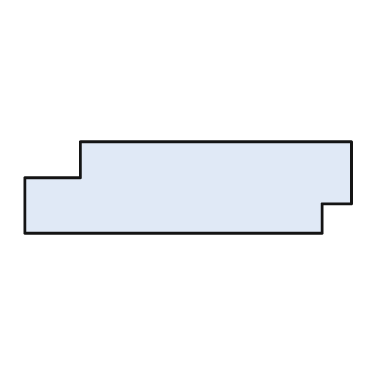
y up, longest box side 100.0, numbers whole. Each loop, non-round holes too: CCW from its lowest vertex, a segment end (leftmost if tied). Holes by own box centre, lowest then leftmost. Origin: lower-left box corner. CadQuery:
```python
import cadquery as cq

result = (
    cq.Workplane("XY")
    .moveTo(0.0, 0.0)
    .lineTo(91.0, 0.0)
    .lineTo(91.0, 9.0)
    .lineTo(100.0, 9.0)
    .lineTo(100.0, 28.0)
    .lineTo(17.0, 28.0)
    .lineTo(17.0, 17.0)
    .lineTo(0.0, 17.0)
    .close()
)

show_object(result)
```